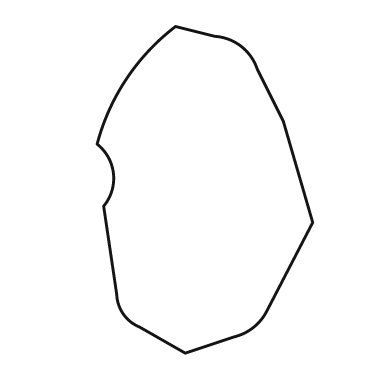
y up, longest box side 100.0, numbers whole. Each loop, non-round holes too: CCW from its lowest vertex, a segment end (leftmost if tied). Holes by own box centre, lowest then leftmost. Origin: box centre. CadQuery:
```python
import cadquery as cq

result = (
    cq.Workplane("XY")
    .moveTo(-6.0, -50.0)
    .lineTo(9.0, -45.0)
    .threePointArc((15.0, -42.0), (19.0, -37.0))
    .lineTo(33.0, -10.0)
    .lineTo(24.0, 21.0)
    .lineTo(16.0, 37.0)
    .threePointArc((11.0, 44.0), (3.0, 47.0))
    .lineTo(-9.0, 50.0)
    .threePointArc((-24.0, 34.0), (-33.0, 14.0))
    .threePointArc((-28.0, 5.0), (-31.0, -5.0))
    .lineTo(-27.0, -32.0)
    .threePointArc((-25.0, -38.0), (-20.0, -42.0))
    .close()
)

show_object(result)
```